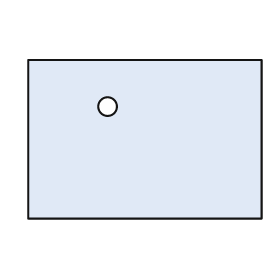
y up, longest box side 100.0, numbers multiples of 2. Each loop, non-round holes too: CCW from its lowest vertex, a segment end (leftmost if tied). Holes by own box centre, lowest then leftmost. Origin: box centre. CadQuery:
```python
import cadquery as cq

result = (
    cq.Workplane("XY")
    .moveTo(-50.0, -34.0)
    .lineTo(50.0, -34.0)
    .lineTo(50.0, 34.0)
    .lineTo(-50.0, 34.0)
    .close()
    .moveTo(-16.0, 14.0)
    .circle(4.0)
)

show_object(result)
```